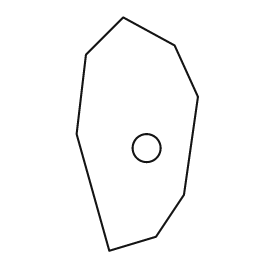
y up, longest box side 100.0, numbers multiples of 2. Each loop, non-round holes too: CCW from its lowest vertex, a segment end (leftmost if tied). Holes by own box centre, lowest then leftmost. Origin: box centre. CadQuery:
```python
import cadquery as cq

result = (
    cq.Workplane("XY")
    .moveTo(-12.0, -50.0)
    .lineTo(8.0, -44.0)
    .lineTo(20.0, -26.0)
    .lineTo(26.0, 16.0)
    .lineTo(16.0, 38.0)
    .lineTo(-6.0, 50.0)
    .lineTo(-22.0, 34.0)
    .lineTo(-26.0, 0.0)
    .close()
    .moveTo(4.0, -6.0)
    .circle(6.0)
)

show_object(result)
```